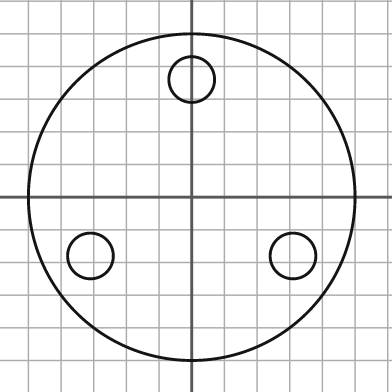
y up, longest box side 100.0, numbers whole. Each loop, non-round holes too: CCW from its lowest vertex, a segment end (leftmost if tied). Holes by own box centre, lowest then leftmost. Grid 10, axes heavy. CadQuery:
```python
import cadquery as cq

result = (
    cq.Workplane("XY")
    .moveTo(0.0, 0.0)
    .circle(50.0)
    .moveTo(-31.0, -18.0)
    .circle(7.0)
    .moveTo(31.0, -18.0)
    .circle(7.0)
    .moveTo(0.0, 36.0)
    .circle(7.0)
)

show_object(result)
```